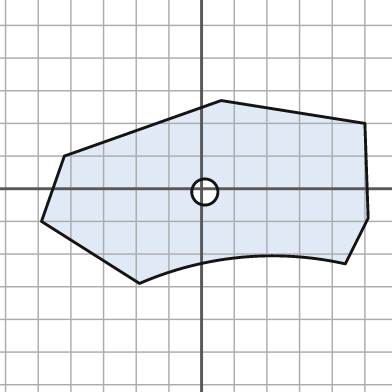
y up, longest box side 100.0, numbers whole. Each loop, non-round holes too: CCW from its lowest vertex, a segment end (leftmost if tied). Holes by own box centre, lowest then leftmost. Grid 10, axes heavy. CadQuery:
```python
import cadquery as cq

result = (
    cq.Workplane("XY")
    .moveTo(-19.0, -29.0)
    .threePointArc((12.0, -21.0), (44.0, -23.0))
    .lineTo(51.0, -9.0)
    .lineTo(50.0, 20.0)
    .lineTo(6.0, 27.0)
    .lineTo(-42.0, 10.0)
    .lineTo(-49.0, -10.0)
    .close()
    .moveTo(1.0, -1.0)
    .circle(4.0)
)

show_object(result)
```